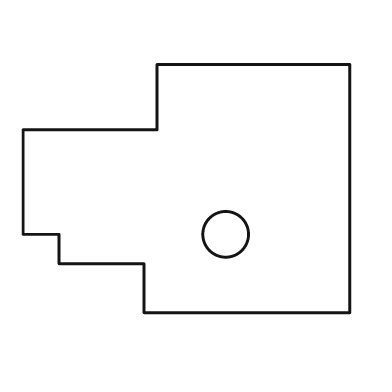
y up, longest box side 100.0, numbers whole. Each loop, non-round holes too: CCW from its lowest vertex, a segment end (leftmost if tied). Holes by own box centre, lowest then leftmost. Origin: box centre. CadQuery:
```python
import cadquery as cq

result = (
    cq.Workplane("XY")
    .moveTo(-13.0, -38.0)
    .lineTo(50.0, -38.0)
    .lineTo(50.0, 38.0)
    .lineTo(-9.0, 38.0)
    .lineTo(-9.0, 18.0)
    .lineTo(-50.0, 18.0)
    .lineTo(-50.0, -14.0)
    .lineTo(-39.0, -14.0)
    .lineTo(-39.0, -23.0)
    .lineTo(-13.0, -23.0)
    .close()
    .moveTo(12.0, -14.0)
    .circle(7.0)
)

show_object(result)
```